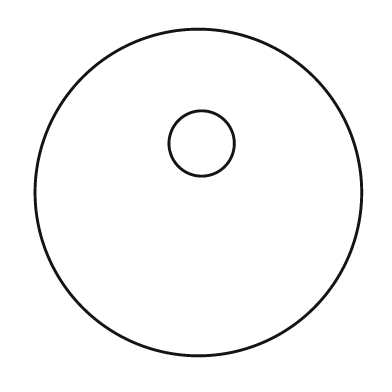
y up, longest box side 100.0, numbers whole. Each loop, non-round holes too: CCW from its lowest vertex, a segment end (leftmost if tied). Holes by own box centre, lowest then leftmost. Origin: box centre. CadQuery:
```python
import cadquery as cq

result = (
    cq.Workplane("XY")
    .moveTo(0.0, 0.0)
    .circle(50.0)
    .moveTo(1.0, 15.0)
    .circle(10.0)
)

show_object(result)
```